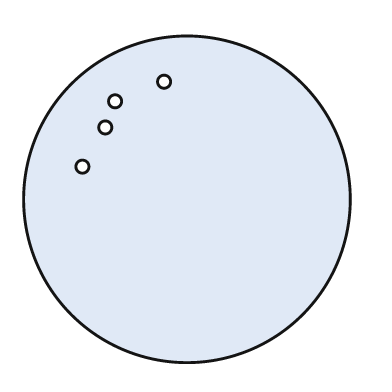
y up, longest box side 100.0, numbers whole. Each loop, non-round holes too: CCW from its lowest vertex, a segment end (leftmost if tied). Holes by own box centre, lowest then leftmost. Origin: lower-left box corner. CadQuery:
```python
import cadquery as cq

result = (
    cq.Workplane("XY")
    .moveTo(50.0, 50.0)
    .circle(50.0)
    .moveTo(18.0, 60.0)
    .circle(2.0)
    .moveTo(25.0, 72.0)
    .circle(2.0)
    .moveTo(28.0, 80.0)
    .circle(2.0)
    .moveTo(43.0, 86.0)
    .circle(2.0)
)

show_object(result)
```